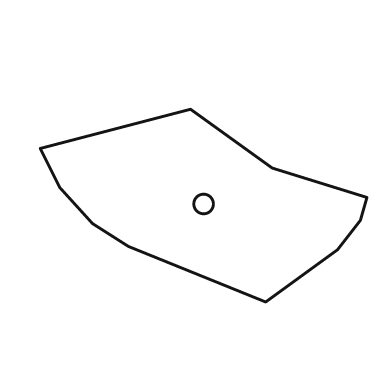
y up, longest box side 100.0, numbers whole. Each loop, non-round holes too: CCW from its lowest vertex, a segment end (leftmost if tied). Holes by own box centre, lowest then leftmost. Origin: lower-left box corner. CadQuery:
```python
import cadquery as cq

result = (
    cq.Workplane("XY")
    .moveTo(69.0, 0.0)
    .lineTo(91.0, 16.0)
    .lineTo(98.0, 25.0)
    .lineTo(100.0, 32.0)
    .lineTo(71.0, 41.0)
    .lineTo(46.0, 59.0)
    .lineTo(0.0, 47.0)
    .lineTo(6.0, 35.0)
    .lineTo(16.0, 24.0)
    .lineTo(27.0, 17.0)
    .close()
    .moveTo(50.0, 30.0)
    .circle(3.0)
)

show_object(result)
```